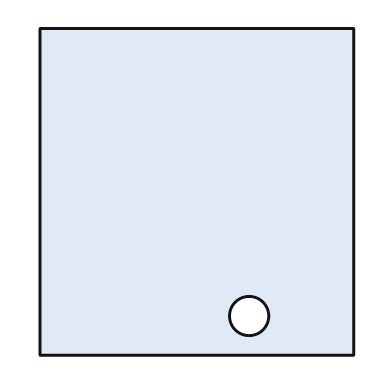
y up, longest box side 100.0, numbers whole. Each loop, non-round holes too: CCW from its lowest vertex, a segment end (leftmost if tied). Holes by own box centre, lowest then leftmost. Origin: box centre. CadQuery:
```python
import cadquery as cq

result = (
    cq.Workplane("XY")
    .moveTo(-48.0, -50.0)
    .lineTo(48.0, -50.0)
    .lineTo(48.0, 50.0)
    .lineTo(-48.0, 50.0)
    .close()
    .moveTo(16.0, -38.0)
    .circle(6.0)
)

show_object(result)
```